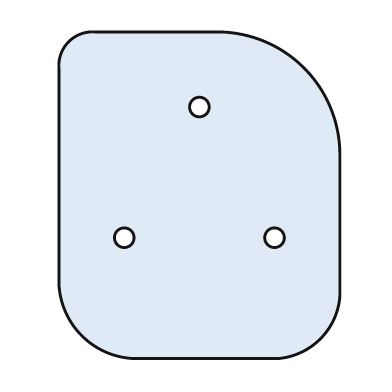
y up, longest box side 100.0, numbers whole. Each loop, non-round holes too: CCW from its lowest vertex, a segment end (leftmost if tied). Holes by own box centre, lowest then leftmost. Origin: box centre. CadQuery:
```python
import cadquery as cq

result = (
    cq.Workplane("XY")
    .moveTo(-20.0, -50.0)
    .lineTo(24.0, -50.0)
    .threePointArc((37.0, -44.0), (43.0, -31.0))
    .lineTo(43.0, 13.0)
    .threePointArc((32.0, 39.0), (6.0, 50.0))
    .lineTo(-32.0, 50.0)
    .threePointArc((-40.0, 47.0), (-43.0, 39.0))
    .lineTo(-43.0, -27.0)
    .threePointArc((-36.0, -43.0), (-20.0, -50.0))
    .close()
    .moveTo(-23.0, -13.0)
    .circle(3.0)
    .moveTo(23.0, -13.0)
    .circle(3.0)
    .moveTo(0.0, 27.0)
    .circle(3.0)
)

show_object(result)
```